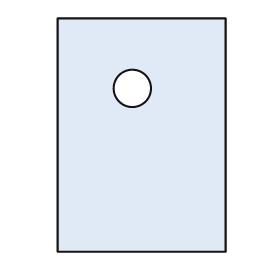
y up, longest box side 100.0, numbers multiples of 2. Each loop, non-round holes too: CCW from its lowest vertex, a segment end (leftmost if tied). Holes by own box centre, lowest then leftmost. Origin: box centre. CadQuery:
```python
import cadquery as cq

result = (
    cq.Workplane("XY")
    .moveTo(-36.0, -50.0)
    .lineTo(36.0, -50.0)
    .lineTo(36.0, 50.0)
    .lineTo(-36.0, 50.0)
    .close()
    .moveTo(-4.0, 20.0)
    .circle(8.0)
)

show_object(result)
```